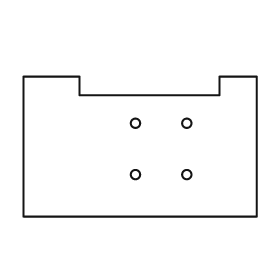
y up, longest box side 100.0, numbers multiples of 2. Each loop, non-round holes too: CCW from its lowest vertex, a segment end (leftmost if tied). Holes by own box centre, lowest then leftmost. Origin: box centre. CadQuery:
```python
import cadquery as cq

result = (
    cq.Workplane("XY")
    .moveTo(-50.0, -30.0)
    .lineTo(50.0, -30.0)
    .lineTo(50.0, 30.0)
    .lineTo(34.0, 30.0)
    .lineTo(34.0, 22.0)
    .lineTo(-26.0, 22.0)
    .lineTo(-26.0, 30.0)
    .lineTo(-50.0, 30.0)
    .close()
    .moveTo(-2.0, -12.0)
    .circle(2.0)
    .moveTo(20.0, -12.0)
    .circle(2.0)
    .moveTo(-2.0, 10.0)
    .circle(2.0)
    .moveTo(20.0, 10.0)
    .circle(2.0)
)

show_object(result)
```